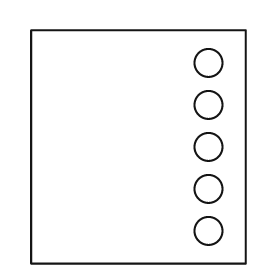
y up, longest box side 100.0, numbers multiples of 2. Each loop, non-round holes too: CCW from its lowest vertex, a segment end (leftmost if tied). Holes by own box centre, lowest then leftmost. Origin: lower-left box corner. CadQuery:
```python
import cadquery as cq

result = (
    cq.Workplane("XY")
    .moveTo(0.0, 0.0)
    .lineTo(92.0, 0.0)
    .lineTo(92.0, 100.0)
    .lineTo(0.0, 100.0)
    .close()
    .moveTo(76.0, 14.0)
    .circle(6.0)
    .moveTo(76.0, 32.0)
    .circle(6.0)
    .moveTo(76.0, 50.0)
    .circle(6.0)
    .moveTo(76.0, 68.0)
    .circle(6.0)
    .moveTo(76.0, 86.0)
    .circle(6.0)
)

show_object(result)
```